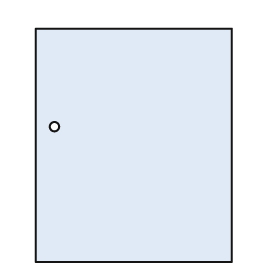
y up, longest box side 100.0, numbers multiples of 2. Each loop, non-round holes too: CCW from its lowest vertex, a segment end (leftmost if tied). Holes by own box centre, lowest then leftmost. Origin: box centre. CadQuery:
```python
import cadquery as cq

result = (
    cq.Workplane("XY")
    .moveTo(-42.0, -50.0)
    .lineTo(42.0, -50.0)
    .lineTo(42.0, 50.0)
    .lineTo(-42.0, 50.0)
    .close()
    .moveTo(-34.0, 8.0)
    .circle(2.0)
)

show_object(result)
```